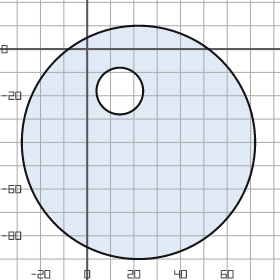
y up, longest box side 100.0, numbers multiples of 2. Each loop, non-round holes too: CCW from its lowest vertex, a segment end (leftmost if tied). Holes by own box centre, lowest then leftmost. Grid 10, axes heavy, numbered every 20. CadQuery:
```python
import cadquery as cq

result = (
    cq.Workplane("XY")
    .moveTo(22.0, -40.0)
    .circle(50.0)
    .moveTo(14.0, -18.0)
    .circle(10.0)
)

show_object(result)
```